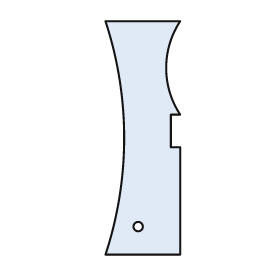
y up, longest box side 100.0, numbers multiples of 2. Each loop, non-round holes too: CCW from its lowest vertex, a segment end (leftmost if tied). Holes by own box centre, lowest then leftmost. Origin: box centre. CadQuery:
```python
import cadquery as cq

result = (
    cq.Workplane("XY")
    .moveTo(-16.0, -50.0)
    .lineTo(16.0, -50.0)
    .lineTo(16.0, -4.0)
    .lineTo(12.0, -4.0)
    .lineTo(12.0, 10.0)
    .lineTo(16.0, 10.0)
    .threePointArc((10.0, 30.0), (16.0, 50.0))
    .lineTo(-16.0, 50.0)
    .threePointArc((-8.0, 0.0), (-16.0, -50.0))
    .close()
    .moveTo(-2.0, -38.0)
    .circle(2.0)
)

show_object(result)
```